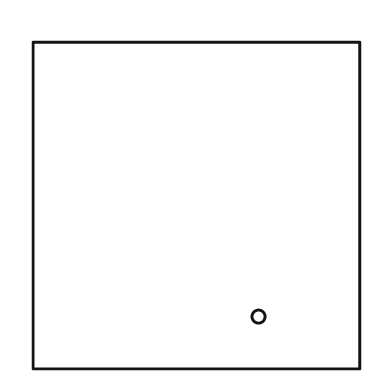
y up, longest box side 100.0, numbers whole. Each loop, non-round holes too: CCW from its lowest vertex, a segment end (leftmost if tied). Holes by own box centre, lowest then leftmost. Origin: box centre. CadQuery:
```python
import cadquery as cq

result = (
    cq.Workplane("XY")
    .moveTo(-50.0, -50.0)
    .lineTo(50.0, -50.0)
    .lineTo(50.0, 50.0)
    .lineTo(-50.0, 50.0)
    .close()
    .moveTo(19.0, -34.0)
    .circle(2.0)
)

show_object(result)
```